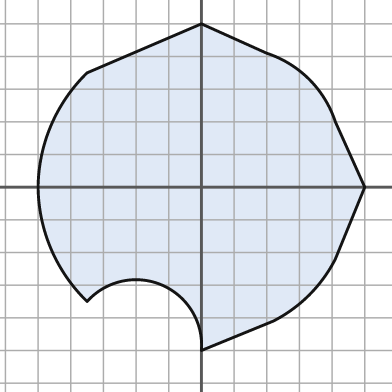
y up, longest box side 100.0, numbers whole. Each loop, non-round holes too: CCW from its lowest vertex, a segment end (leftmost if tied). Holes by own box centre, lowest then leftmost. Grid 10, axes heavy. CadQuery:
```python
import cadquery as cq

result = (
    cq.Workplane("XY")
    .moveTo(0.0, -50.0)
    .lineTo(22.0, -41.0)
    .threePointArc((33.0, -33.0), (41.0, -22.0))
    .lineTo(50.0, 0.0)
    .lineTo(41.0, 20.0)
    .threePointArc((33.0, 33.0), (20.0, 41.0))
    .lineTo(0.0, 50.0)
    .lineTo(-35.0, 35.0)
    .threePointArc((-46.0, 19.0), (-50.0, 0.0))
    .threePointArc((-46.0, -19.0), (-35.0, -35.0))
    .threePointArc((-12.0, -30.0), (0.0, -50.0))
    .close()
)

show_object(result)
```